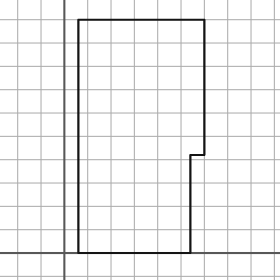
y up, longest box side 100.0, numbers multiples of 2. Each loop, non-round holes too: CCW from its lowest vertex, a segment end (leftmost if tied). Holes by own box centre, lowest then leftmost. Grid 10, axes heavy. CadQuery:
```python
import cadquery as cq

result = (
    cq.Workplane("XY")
    .moveTo(6.0, 0.0)
    .lineTo(54.0, 0.0)
    .lineTo(54.0, 42.0)
    .lineTo(60.0, 42.0)
    .lineTo(60.0, 100.0)
    .lineTo(6.0, 100.0)
    .close()
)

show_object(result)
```